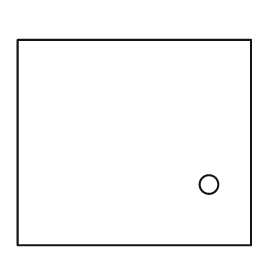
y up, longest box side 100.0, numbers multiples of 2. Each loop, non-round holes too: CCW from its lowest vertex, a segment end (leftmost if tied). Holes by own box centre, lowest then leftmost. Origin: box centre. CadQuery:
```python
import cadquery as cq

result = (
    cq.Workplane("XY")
    .moveTo(-50.0, -44.0)
    .lineTo(50.0, -44.0)
    .lineTo(50.0, 44.0)
    .lineTo(-50.0, 44.0)
    .close()
    .moveTo(32.0, -18.0)
    .circle(4.0)
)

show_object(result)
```